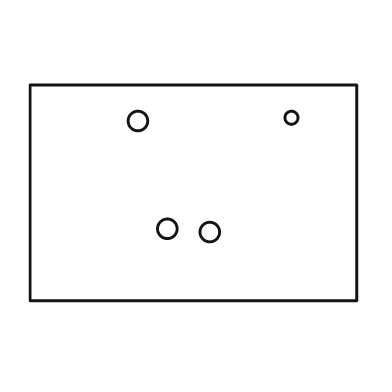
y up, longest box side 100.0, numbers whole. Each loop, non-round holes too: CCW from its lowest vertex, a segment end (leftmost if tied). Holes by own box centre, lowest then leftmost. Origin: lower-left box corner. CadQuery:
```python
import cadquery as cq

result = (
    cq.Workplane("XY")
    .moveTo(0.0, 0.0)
    .lineTo(100.0, 0.0)
    .lineTo(100.0, 66.0)
    .lineTo(0.0, 66.0)
    .close()
    .moveTo(55.0, 21.0)
    .circle(3.0)
    .moveTo(42.0, 22.0)
    .circle(3.0)
    .moveTo(33.0, 55.0)
    .circle(3.0)
    .moveTo(80.0, 56.0)
    .circle(2.0)
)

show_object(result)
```